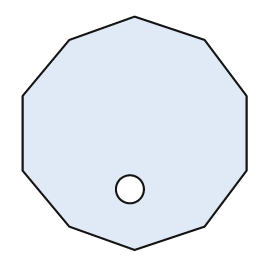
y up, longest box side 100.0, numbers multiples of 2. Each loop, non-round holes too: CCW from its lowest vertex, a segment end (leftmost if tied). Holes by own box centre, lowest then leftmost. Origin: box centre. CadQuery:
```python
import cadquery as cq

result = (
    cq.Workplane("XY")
    .moveTo(0.0, -50.0)
    .lineTo(30.0, -40.0)
    .lineTo(48.0, -16.0)
    .lineTo(48.0, 16.0)
    .lineTo(30.0, 40.0)
    .lineTo(0.0, 50.0)
    .lineTo(-28.0, 40.0)
    .lineTo(-48.0, 16.0)
    .lineTo(-48.0, -16.0)
    .lineTo(-28.0, -40.0)
    .close()
    .moveTo(-2.0, -24.0)
    .circle(6.0)
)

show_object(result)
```